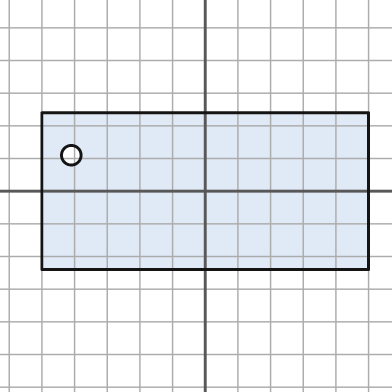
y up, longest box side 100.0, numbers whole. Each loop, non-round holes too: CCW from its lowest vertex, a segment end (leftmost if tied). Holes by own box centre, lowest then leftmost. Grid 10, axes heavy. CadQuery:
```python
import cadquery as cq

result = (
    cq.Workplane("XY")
    .moveTo(-50.0, -24.0)
    .lineTo(50.0, -24.0)
    .lineTo(50.0, 24.0)
    .lineTo(-50.0, 24.0)
    .close()
    .moveTo(-41.0, 11.0)
    .circle(3.0)
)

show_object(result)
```